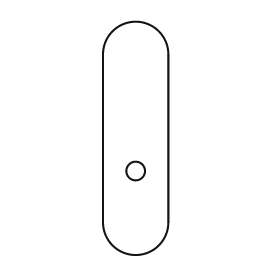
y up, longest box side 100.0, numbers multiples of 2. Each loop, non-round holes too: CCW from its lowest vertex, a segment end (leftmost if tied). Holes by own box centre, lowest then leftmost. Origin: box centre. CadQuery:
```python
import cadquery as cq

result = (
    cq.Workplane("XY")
    .moveTo(-14.0, -36.0)
    .threePointArc((0.0, -50.0), (14.0, -36.0))
    .lineTo(14.0, 36.0)
    .threePointArc((0.0, 50.0), (-14.0, 36.0))
    .close()
    .moveTo(0.0, -14.0)
    .circle(4.0)
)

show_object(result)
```